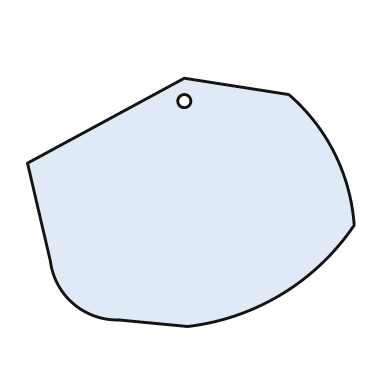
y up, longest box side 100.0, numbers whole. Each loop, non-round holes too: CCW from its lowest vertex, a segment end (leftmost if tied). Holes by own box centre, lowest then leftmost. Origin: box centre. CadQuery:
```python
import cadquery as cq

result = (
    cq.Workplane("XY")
    .moveTo(-1.0, -38.0)
    .threePointArc((28.0, -28.0), (50.0, -7.0))
    .threePointArc((44.0, 15.0), (30.0, 33.0))
    .lineTo(-2.0, 38.0)
    .lineTo(-50.0, 12.0)
    .lineTo(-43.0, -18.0)
    .threePointArc((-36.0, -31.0), (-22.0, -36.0))
    .close()
    .moveTo(-2.0, 31.0)
    .circle(2.0)
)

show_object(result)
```